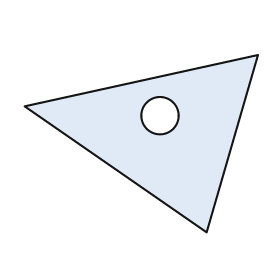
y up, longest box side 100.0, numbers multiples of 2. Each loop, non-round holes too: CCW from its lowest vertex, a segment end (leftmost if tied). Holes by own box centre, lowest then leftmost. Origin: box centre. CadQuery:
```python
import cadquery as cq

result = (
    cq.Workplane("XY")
    .moveTo(28.0, -38.0)
    .lineTo(50.0, 38.0)
    .lineTo(-50.0, 16.0)
    .close()
    .moveTo(8.0, 12.0)
    .circle(8.0)
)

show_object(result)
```